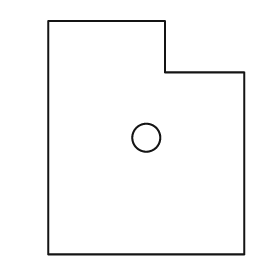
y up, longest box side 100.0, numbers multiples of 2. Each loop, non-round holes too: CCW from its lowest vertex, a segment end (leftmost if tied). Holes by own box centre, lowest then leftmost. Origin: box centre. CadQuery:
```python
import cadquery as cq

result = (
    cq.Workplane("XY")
    .moveTo(-42.0, -50.0)
    .lineTo(42.0, -50.0)
    .lineTo(42.0, 28.0)
    .lineTo(8.0, 28.0)
    .lineTo(8.0, 50.0)
    .lineTo(-42.0, 50.0)
    .close()
    .moveTo(0.0, 0.0)
    .circle(6.0)
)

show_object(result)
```